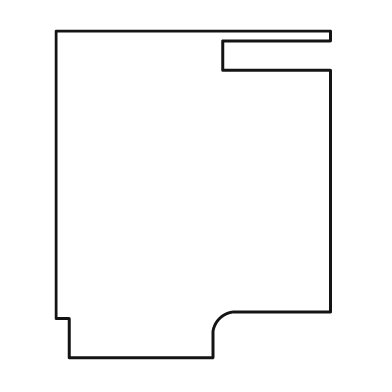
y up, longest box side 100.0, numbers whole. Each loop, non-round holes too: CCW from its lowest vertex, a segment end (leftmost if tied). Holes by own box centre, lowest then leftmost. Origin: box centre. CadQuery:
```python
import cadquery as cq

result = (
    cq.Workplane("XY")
    .moveTo(-38.0, -50.0)
    .lineTo(6.0, -50.0)
    .lineTo(6.0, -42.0)
    .threePointArc((8.0, -38.0), (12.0, -36.0))
    .lineTo(42.0, -36.0)
    .lineTo(42.0, 38.0)
    .lineTo(9.0, 38.0)
    .lineTo(9.0, 47.0)
    .lineTo(42.0, 47.0)
    .lineTo(42.0, 50.0)
    .lineTo(-42.0, 50.0)
    .lineTo(-42.0, -38.0)
    .lineTo(-38.0, -38.0)
    .close()
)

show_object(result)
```